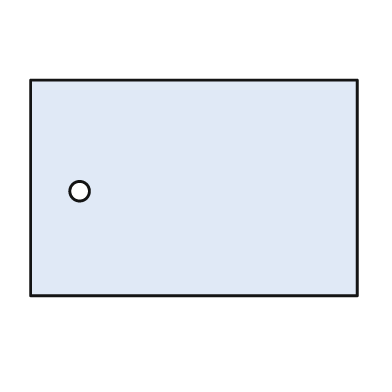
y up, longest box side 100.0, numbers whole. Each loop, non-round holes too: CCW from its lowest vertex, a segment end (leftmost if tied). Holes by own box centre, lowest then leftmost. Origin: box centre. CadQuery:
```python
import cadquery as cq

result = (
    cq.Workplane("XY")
    .moveTo(-50.0, -33.0)
    .lineTo(50.0, -33.0)
    .lineTo(50.0, 33.0)
    .lineTo(-50.0, 33.0)
    .close()
    .moveTo(-35.0, -1.0)
    .circle(3.0)
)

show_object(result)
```